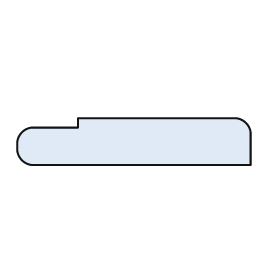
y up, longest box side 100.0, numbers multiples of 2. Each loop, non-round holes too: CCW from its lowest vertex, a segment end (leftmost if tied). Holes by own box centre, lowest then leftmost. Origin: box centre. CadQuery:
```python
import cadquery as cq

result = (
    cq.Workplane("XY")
    .moveTo(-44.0, -10.0)
    .lineTo(50.0, -10.0)
    .lineTo(50.0, 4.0)
    .threePointArc((48.0, 8.0), (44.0, 10.0))
    .lineTo(-24.0, 10.0)
    .lineTo(-24.0, 6.0)
    .lineTo(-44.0, 6.0)
    .threePointArc((-48.0, 4.0), (-50.0, 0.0))
    .lineTo(-50.0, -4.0)
    .threePointArc((-48.0, -8.0), (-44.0, -10.0))
    .close()
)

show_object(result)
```